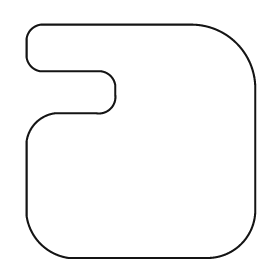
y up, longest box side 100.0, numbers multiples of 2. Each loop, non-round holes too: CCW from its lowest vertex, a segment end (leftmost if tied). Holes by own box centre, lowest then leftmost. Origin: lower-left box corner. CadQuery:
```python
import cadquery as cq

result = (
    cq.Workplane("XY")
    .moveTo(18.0, 0.0)
    .lineTo(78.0, 0.0)
    .threePointArc((92.0, 6.0), (98.0, 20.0))
    .lineTo(98.0, 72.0)
    .threePointArc((90.0, 92.0), (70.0, 100.0))
    .lineTo(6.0, 100.0)
    .threePointArc((2.0, 98.0), (0.0, 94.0))
    .lineTo(0.0, 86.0)
    .threePointArc((2.0, 82.0), (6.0, 80.0))
    .lineTo(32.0, 80.0)
    .threePointArc((36.0, 78.0), (38.0, 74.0))
    .lineTo(38.0, 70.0)
    .threePointArc((36.0, 64.0), (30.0, 62.0))
    .lineTo(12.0, 62.0)
    .threePointArc((4.0, 58.0), (0.0, 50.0))
    .lineTo(0.0, 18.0)
    .threePointArc((6.0, 6.0), (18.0, 0.0))
    .close()
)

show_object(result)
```